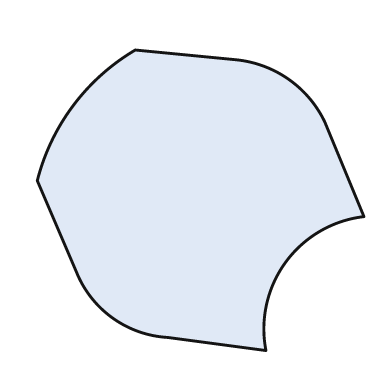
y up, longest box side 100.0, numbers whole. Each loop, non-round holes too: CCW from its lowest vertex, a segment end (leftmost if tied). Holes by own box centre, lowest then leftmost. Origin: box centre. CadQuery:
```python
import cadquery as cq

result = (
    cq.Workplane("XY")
    .moveTo(20.0, -46.0)
    .threePointArc((26.0, -19.0), (50.0, -5.0))
    .lineTo(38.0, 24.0)
    .threePointArc((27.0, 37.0), (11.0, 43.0))
    .lineTo(-20.0, 46.0)
    .threePointArc((-39.0, 29.0), (-50.0, 6.0))
    .lineTo(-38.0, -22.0)
    .threePointArc((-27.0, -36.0), (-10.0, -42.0))
    .close()
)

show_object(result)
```